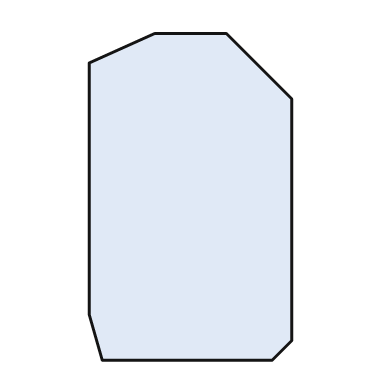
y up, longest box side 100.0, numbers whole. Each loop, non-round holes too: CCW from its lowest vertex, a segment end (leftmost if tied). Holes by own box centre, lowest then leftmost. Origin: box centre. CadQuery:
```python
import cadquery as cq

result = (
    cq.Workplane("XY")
    .moveTo(-27.0, -50.0)
    .lineTo(25.0, -50.0)
    .lineTo(31.0, -44.0)
    .lineTo(31.0, 30.0)
    .lineTo(11.0, 50.0)
    .lineTo(-11.0, 50.0)
    .lineTo(-31.0, 41.0)
    .lineTo(-31.0, -36.0)
    .close()
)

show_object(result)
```